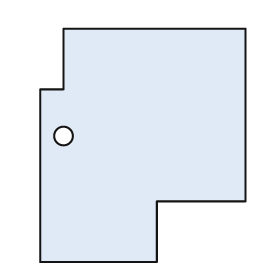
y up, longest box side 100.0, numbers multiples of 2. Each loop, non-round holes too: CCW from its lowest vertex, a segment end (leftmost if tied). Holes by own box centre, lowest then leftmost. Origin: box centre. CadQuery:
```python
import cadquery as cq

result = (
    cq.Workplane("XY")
    .moveTo(-44.0, -50.0)
    .lineTo(6.0, -50.0)
    .lineTo(6.0, -24.0)
    .lineTo(44.0, -24.0)
    .lineTo(44.0, 50.0)
    .lineTo(-34.0, 50.0)
    .lineTo(-34.0, 24.0)
    .lineTo(-44.0, 24.0)
    .close()
    .moveTo(-34.0, 4.0)
    .circle(4.0)
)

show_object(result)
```